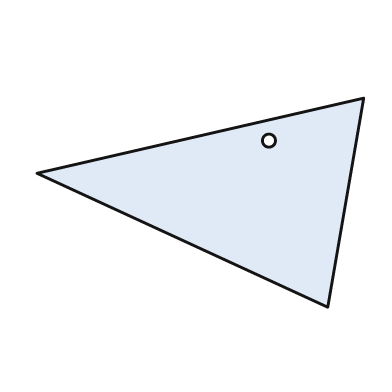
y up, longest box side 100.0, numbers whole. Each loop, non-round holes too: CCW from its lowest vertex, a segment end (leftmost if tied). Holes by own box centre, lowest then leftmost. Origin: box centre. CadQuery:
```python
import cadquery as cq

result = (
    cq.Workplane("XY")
    .moveTo(39.0, -32.0)
    .lineTo(50.0, 32.0)
    .lineTo(-50.0, 9.0)
    .close()
    .moveTo(21.0, 19.0)
    .circle(2.0)
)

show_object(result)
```